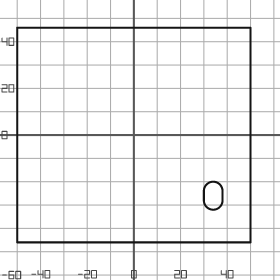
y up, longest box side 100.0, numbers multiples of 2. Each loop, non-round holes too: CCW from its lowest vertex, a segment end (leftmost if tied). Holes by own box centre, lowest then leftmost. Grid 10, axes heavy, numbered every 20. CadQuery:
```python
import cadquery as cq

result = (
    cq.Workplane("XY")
    .moveTo(-50.0, -46.0)
    .lineTo(50.0, -46.0)
    .lineTo(50.0, 46.0)
    .lineTo(-50.0, 46.0)
    .close()
    .moveTo(30.0, -28.0)
    .threePointArc((34.0, -32.0), (38.0, -28.0))
    .lineTo(38.0, -24.0)
    .threePointArc((34.0, -20.0), (30.0, -24.0))
    .close()
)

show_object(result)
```